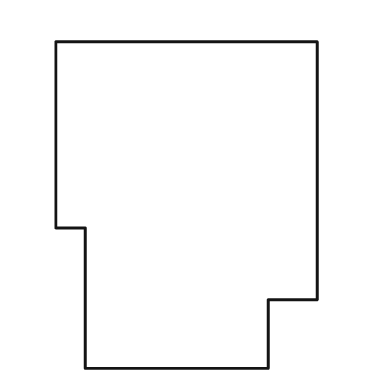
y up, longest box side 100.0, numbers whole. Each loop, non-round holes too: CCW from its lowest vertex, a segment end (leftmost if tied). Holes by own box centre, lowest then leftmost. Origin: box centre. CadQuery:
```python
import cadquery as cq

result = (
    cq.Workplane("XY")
    .moveTo(-31.0, -50.0)
    .lineTo(25.0, -50.0)
    .lineTo(25.0, -29.0)
    .lineTo(40.0, -29.0)
    .lineTo(40.0, 50.0)
    .lineTo(-40.0, 50.0)
    .lineTo(-40.0, -7.0)
    .lineTo(-31.0, -7.0)
    .close()
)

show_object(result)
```